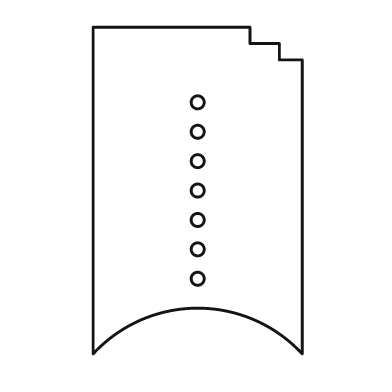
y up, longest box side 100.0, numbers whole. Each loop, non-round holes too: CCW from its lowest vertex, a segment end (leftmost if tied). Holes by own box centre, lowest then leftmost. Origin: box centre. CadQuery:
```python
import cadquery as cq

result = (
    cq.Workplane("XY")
    .moveTo(-32.0, -50.0)
    .threePointArc((0.0, -36.0), (32.0, -50.0))
    .lineTo(32.0, 40.0)
    .lineTo(25.0, 40.0)
    .lineTo(25.0, 45.0)
    .lineTo(16.0, 45.0)
    .lineTo(16.0, 50.0)
    .lineTo(-32.0, 50.0)
    .close()
    .moveTo(0.0, -27.0)
    .circle(2.0)
    .moveTo(0.0, -18.0)
    .circle(2.0)
    .moveTo(0.0, -9.0)
    .circle(2.0)
    .moveTo(0.0, 0.0)
    .circle(2.0)
    .moveTo(0.0, 9.0)
    .circle(2.0)
    .moveTo(0.0, 18.0)
    .circle(2.0)
    .moveTo(0.0, 27.0)
    .circle(2.0)
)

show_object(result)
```